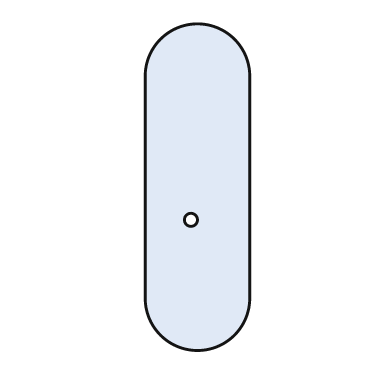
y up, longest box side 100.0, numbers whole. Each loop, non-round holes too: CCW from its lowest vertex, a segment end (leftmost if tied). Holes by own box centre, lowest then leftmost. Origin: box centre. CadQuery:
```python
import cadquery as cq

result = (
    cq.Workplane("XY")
    .moveTo(-16.0, -34.0)
    .threePointArc((0.0, -50.0), (16.0, -34.0))
    .lineTo(16.0, 34.0)
    .threePointArc((0.0, 50.0), (-16.0, 34.0))
    .close()
    .moveTo(-2.0, -10.0)
    .circle(2.0)
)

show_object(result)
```